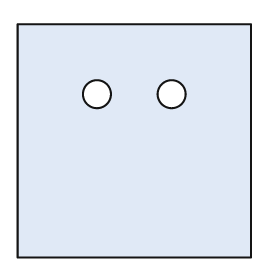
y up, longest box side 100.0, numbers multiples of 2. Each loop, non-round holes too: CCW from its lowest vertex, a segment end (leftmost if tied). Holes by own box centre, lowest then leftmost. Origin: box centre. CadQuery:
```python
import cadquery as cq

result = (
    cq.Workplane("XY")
    .moveTo(-50.0, -50.0)
    .lineTo(50.0, -50.0)
    .lineTo(50.0, 50.0)
    .lineTo(-50.0, 50.0)
    .close()
    .moveTo(-16.0, 20.0)
    .circle(6.0)
    .moveTo(16.0, 20.0)
    .circle(6.0)
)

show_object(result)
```